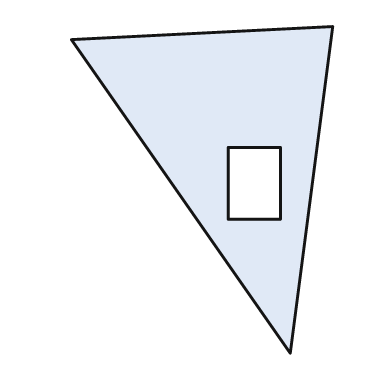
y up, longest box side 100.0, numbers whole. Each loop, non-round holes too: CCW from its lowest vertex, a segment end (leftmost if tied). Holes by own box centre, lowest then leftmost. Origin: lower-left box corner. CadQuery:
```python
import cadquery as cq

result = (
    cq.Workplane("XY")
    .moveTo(67.0, 0.0)
    .lineTo(80.0, 100.0)
    .lineTo(0.0, 96.0)
    .close()
    .moveTo(48.0, 41.0)
    .lineTo(64.0, 41.0)
    .lineTo(64.0, 63.0)
    .lineTo(48.0, 63.0)
    .close()
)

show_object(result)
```